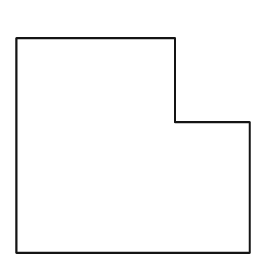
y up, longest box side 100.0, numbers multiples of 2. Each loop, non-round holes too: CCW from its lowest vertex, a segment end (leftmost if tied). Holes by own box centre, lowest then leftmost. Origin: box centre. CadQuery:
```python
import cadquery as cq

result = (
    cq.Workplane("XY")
    .moveTo(-50.0, -46.0)
    .lineTo(50.0, -46.0)
    .lineTo(50.0, 10.0)
    .lineTo(18.0, 10.0)
    .lineTo(18.0, 46.0)
    .lineTo(-50.0, 46.0)
    .close()
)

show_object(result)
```